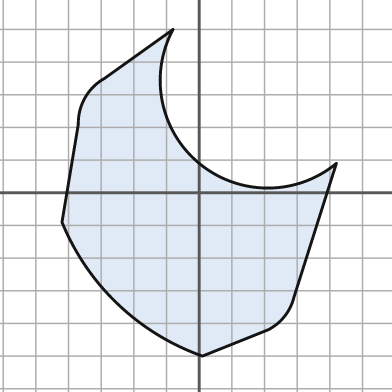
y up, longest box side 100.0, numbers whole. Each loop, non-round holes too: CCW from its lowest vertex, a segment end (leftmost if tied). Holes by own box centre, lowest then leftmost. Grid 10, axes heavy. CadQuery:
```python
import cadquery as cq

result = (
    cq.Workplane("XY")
    .moveTo(1.0, -50.0)
    .lineTo(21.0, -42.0)
    .threePointArc((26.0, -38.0), (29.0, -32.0))
    .lineTo(42.0, 9.0)
    .threePointArc((0.0, 9.0), (-8.0, 50.0))
    .lineTo(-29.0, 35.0)
    .threePointArc((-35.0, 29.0), (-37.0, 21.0))
    .lineTo(-42.0, -9.0)
    .threePointArc((-25.0, -34.0), (1.0, -50.0))
    .close()
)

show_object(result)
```